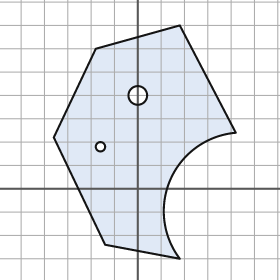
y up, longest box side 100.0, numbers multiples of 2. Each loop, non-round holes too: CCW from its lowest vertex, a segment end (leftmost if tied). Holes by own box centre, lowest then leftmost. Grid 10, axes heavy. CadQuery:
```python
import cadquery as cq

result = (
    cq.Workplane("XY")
    .moveTo(18.0, -30.0)
    .threePointArc((14.0, 4.0), (42.0, 24.0))
    .lineTo(18.0, 70.0)
    .lineTo(-18.0, 60.0)
    .lineTo(-36.0, 22.0)
    .lineTo(-14.0, -24.0)
    .close()
    .moveTo(-16.0, 18.0)
    .circle(2.0)
    .moveTo(0.0, 40.0)
    .circle(4.0)
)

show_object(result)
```